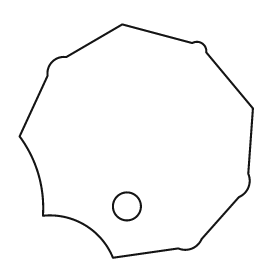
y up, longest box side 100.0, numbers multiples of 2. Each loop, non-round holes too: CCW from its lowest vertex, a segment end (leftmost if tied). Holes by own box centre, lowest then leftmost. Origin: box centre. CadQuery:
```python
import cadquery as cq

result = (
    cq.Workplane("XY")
    .moveTo(-10.0, -50.0)
    .lineTo(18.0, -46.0)
    .threePointArc((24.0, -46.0), (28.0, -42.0))
    .lineTo(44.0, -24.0)
    .threePointArc((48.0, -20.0), (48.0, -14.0))
    .lineTo(50.0, 14.0)
    .lineTo(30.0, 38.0)
    .threePointArc((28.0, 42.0), (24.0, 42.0))
    .lineTo(-6.0, 50.0)
    .lineTo(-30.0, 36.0)
    .threePointArc((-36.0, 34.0), (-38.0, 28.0))
    .lineTo(-50.0, 2.0)
    .threePointArc((-42.0, -14.0), (-40.0, -32.0))
    .threePointArc((-22.0, -36.0), (-10.0, -50.0))
    .close()
    .moveTo(-4.0, -28.0)
    .circle(6.0)
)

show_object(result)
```